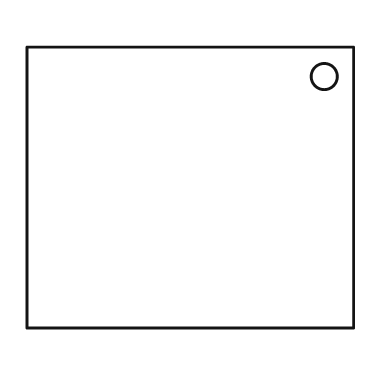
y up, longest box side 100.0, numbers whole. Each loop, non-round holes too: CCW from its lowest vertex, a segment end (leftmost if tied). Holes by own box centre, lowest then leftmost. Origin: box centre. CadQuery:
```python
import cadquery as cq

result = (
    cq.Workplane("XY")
    .moveTo(-50.0, -43.0)
    .lineTo(50.0, -43.0)
    .lineTo(50.0, 43.0)
    .lineTo(-50.0, 43.0)
    .close()
    .moveTo(41.0, 34.0)
    .circle(4.0)
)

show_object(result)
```